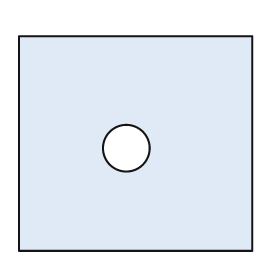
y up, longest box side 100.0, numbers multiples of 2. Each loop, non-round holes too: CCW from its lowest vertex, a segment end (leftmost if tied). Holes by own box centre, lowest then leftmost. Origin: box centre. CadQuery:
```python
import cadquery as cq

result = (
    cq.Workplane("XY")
    .moveTo(-50.0, -46.0)
    .lineTo(50.0, -46.0)
    .lineTo(50.0, 46.0)
    .lineTo(-50.0, 46.0)
    .close()
    .moveTo(-4.0, -2.0)
    .circle(10.0)
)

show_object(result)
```